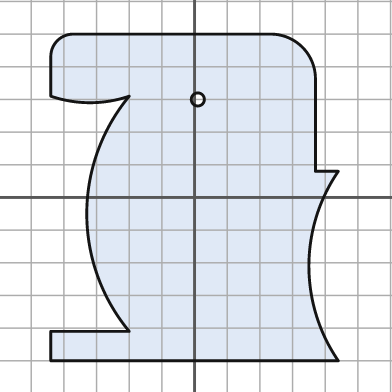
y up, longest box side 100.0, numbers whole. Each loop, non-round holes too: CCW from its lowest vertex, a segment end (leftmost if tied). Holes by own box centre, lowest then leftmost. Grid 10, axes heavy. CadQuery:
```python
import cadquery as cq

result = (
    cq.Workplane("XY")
    .moveTo(-44.0, -50.0)
    .lineTo(44.0, -50.0)
    .threePointArc((35.0, -21.0), (44.0, 8.0))
    .lineTo(37.0, 8.0)
    .lineTo(37.0, 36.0)
    .threePointArc((33.0, 46.0), (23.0, 50.0))
    .lineTo(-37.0, 50.0)
    .threePointArc((-42.0, 48.0), (-44.0, 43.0))
    .lineTo(-44.0, 31.0)
    .threePointArc((-32.0, 29.0), (-20.0, 31.0))
    .threePointArc((-33.0, -5.0), (-20.0, -41.0))
    .lineTo(-44.0, -41.0)
    .close()
    .moveTo(1.0, 30.0)
    .circle(2.0)
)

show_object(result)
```